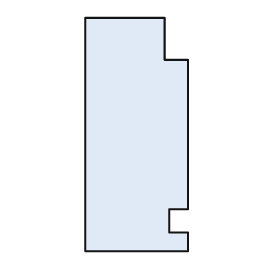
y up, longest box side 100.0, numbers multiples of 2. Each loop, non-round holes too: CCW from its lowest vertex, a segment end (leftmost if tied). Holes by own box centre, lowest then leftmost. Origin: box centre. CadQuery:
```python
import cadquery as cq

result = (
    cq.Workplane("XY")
    .moveTo(-22.0, -50.0)
    .lineTo(22.0, -50.0)
    .lineTo(22.0, -42.0)
    .lineTo(14.0, -42.0)
    .lineTo(14.0, -32.0)
    .lineTo(22.0, -32.0)
    .lineTo(22.0, 32.0)
    .lineTo(12.0, 32.0)
    .lineTo(12.0, 50.0)
    .lineTo(-22.0, 50.0)
    .close()
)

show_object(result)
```